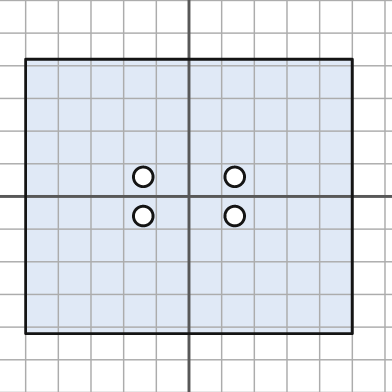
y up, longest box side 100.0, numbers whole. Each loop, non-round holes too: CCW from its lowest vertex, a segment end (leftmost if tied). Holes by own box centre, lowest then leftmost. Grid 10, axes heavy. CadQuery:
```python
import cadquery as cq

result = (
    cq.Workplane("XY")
    .moveTo(-50.0, -42.0)
    .lineTo(50.0, -42.0)
    .lineTo(50.0, 42.0)
    .lineTo(-50.0, 42.0)
    .close()
    .moveTo(-14.0, -6.0)
    .circle(3.0)
    .moveTo(14.0, -6.0)
    .circle(3.0)
    .moveTo(-14.0, 6.0)
    .circle(3.0)
    .moveTo(14.0, 6.0)
    .circle(3.0)
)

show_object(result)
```